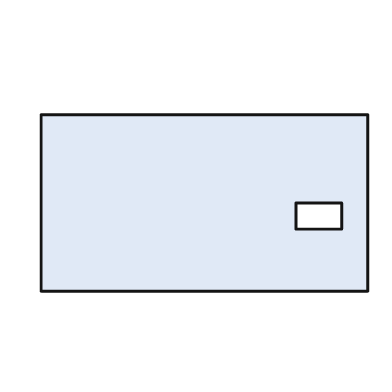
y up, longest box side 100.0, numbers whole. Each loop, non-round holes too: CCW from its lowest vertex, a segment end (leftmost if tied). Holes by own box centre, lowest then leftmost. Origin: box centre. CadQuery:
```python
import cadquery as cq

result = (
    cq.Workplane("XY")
    .moveTo(-50.0, -27.0)
    .lineTo(50.0, -27.0)
    .lineTo(50.0, 27.0)
    .lineTo(-50.0, 27.0)
    .close()
    .moveTo(28.0, -8.0)
    .lineTo(42.0, -8.0)
    .lineTo(42.0, 0.0)
    .lineTo(28.0, 0.0)
    .close()
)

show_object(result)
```